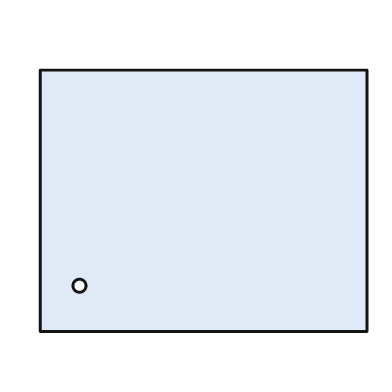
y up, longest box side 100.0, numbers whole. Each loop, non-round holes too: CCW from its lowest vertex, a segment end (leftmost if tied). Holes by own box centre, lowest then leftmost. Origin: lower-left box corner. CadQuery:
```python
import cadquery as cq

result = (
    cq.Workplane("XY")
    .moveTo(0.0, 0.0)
    .lineTo(100.0, 0.0)
    .lineTo(100.0, 80.0)
    .lineTo(0.0, 80.0)
    .close()
    .moveTo(12.0, 14.0)
    .circle(2.0)
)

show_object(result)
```